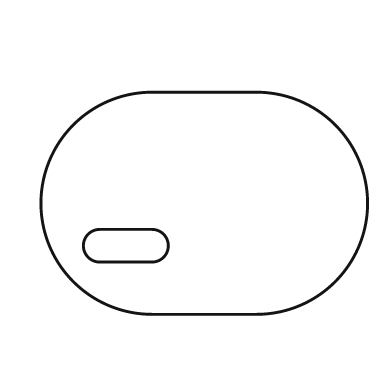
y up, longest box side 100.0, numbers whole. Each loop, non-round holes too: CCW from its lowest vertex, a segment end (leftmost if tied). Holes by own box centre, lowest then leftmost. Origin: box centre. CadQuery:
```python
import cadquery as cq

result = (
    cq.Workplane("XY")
    .moveTo(-16.0, -34.0)
    .lineTo(16.0, -34.0)
    .threePointArc((50.0, 0.0), (16.0, 34.0))
    .lineTo(-16.0, 34.0)
    .threePointArc((-50.0, 0.0), (-16.0, -34.0))
    .close()
    .moveTo(-32.0, -18.0)
    .lineTo(-16.0, -18.0)
    .threePointArc((-11.0, -13.0), (-16.0, -8.0))
    .lineTo(-32.0, -8.0)
    .threePointArc((-37.0, -13.0), (-32.0, -18.0))
    .close()
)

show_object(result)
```